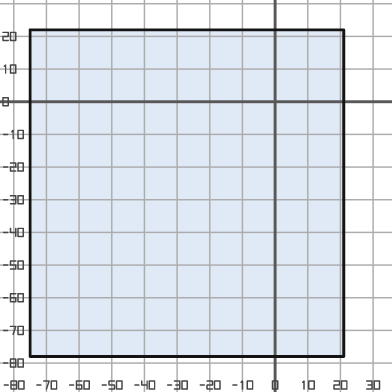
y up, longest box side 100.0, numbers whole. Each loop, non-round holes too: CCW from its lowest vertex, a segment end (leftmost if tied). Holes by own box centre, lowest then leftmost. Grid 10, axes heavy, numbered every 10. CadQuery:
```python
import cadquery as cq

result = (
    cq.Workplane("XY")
    .moveTo(-75.0, -78.0)
    .lineTo(21.0, -78.0)
    .lineTo(21.0, 22.0)
    .lineTo(-75.0, 22.0)
    .close()
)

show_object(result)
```